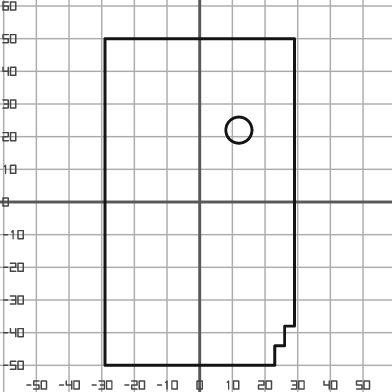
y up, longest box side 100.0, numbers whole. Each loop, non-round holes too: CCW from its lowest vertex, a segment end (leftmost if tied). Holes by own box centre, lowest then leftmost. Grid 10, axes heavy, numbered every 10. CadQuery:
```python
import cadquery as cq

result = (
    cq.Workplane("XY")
    .moveTo(-29.0, -50.0)
    .lineTo(23.0, -50.0)
    .lineTo(23.0, -44.0)
    .lineTo(26.0, -44.0)
    .lineTo(26.0, -38.0)
    .lineTo(29.0, -38.0)
    .lineTo(29.0, 50.0)
    .lineTo(-29.0, 50.0)
    .close()
    .moveTo(12.0, 22.0)
    .circle(4.0)
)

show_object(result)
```